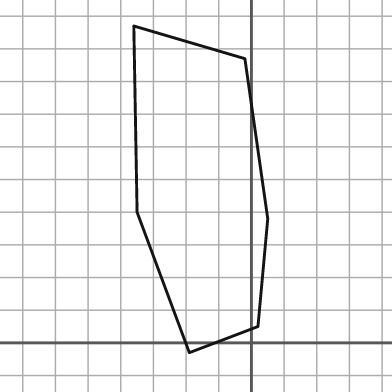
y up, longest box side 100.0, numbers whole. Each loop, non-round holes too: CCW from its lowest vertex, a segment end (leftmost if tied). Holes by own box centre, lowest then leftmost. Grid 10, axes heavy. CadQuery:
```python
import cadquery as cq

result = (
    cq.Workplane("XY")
    .moveTo(-19.0, -3.0)
    .lineTo(2.0, 5.0)
    .lineTo(5.0, 38.0)
    .lineTo(-2.0, 87.0)
    .lineTo(-36.0, 97.0)
    .lineTo(-35.0, 40.0)
    .close()
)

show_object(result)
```